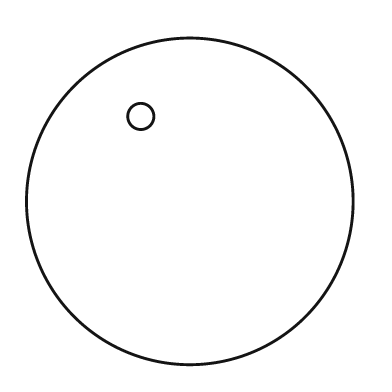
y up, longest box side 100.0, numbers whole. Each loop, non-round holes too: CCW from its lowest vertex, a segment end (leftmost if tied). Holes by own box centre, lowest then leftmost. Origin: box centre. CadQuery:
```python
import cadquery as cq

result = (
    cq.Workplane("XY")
    .moveTo(0.0, 0.0)
    .circle(50.0)
    .moveTo(-15.0, 26.0)
    .circle(4.0)
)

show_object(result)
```